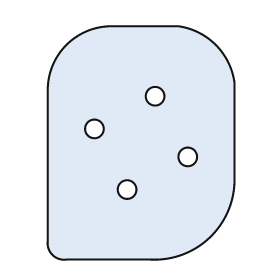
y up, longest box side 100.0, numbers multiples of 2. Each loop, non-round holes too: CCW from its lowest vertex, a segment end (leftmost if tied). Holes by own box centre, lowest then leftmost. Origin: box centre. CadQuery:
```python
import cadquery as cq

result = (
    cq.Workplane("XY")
    .moveTo(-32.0, -50.0)
    .lineTo(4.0, -50.0)
    .threePointArc((30.0, -40.0), (40.0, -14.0))
    .lineTo(40.0, 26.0)
    .threePointArc((32.0, 42.0), (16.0, 50.0))
    .lineTo(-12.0, 50.0)
    .threePointArc((-32.0, 42.0), (-40.0, 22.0))
    .lineTo(-40.0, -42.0)
    .threePointArc((-38.0, -48.0), (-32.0, -50.0))
    .close()
    .moveTo(-6.0, -20.0)
    .circle(4.0)
    .moveTo(20.0, -6.0)
    .circle(4.0)
    .moveTo(-20.0, 6.0)
    .circle(4.0)
    .moveTo(6.0, 20.0)
    .circle(4.0)
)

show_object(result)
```